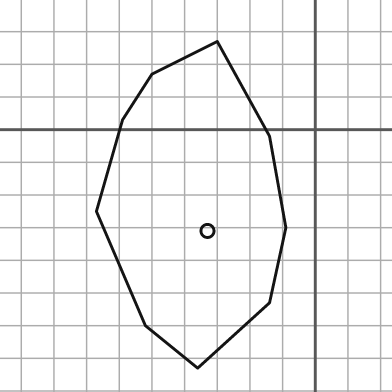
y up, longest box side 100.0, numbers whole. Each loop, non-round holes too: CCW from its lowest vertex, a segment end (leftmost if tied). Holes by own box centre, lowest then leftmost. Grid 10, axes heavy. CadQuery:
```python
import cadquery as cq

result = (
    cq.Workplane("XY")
    .moveTo(-36.0, -73.0)
    .lineTo(-14.0, -53.0)
    .lineTo(-9.0, -30.0)
    .lineTo(-14.0, -2.0)
    .lineTo(-30.0, 27.0)
    .lineTo(-50.0, 17.0)
    .lineTo(-59.0, 3.0)
    .lineTo(-67.0, -25.0)
    .lineTo(-52.0, -60.0)
    .close()
    .moveTo(-33.0, -31.0)
    .circle(2.0)
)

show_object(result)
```